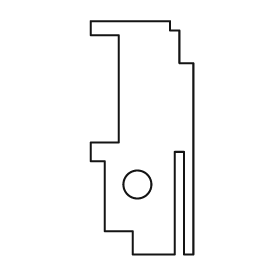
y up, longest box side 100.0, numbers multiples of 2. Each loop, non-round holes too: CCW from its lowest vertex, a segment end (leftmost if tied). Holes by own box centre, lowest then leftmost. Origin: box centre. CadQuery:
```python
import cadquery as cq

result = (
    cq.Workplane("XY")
    .moveTo(-4.0, -50.0)
    .lineTo(14.0, -50.0)
    .lineTo(14.0, -6.0)
    .lineTo(18.0, -6.0)
    .lineTo(18.0, -50.0)
    .lineTo(22.0, -50.0)
    .lineTo(22.0, 32.0)
    .lineTo(16.0, 32.0)
    .lineTo(16.0, 46.0)
    .lineTo(12.0, 46.0)
    .lineTo(12.0, 50.0)
    .lineTo(-22.0, 50.0)
    .lineTo(-22.0, 44.0)
    .lineTo(-10.0, 44.0)
    .lineTo(-10.0, -2.0)
    .lineTo(-22.0, -2.0)
    .lineTo(-22.0, -10.0)
    .lineTo(-16.0, -10.0)
    .lineTo(-16.0, -40.0)
    .lineTo(-4.0, -40.0)
    .close()
    .moveTo(-2.0, -20.0)
    .circle(6.0)
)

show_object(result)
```